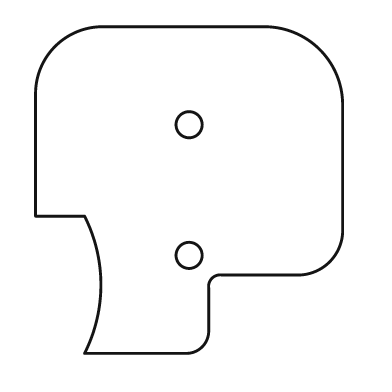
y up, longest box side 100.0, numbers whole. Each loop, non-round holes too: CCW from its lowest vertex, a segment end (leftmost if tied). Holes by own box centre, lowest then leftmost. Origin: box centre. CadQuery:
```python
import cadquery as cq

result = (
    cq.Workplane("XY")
    .moveTo(-32.0, -50.0)
    .lineTo(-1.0, -50.0)
    .threePointArc((4.0, -48.0), (6.0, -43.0))
    .lineTo(6.0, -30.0)
    .threePointArc((7.0, -27.0), (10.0, -26.0))
    .lineTo(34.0, -26.0)
    .threePointArc((43.0, -22.0), (47.0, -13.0))
    .lineTo(47.0, 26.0)
    .threePointArc((40.0, 43.0), (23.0, 50.0))
    .lineTo(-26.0, 50.0)
    .threePointArc((-41.0, 44.0), (-47.0, 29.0))
    .lineTo(-47.0, -8.0)
    .lineTo(-32.0, -8.0)
    .threePointArc((-27.0, -29.0), (-32.0, -50.0))
    .close()
    .moveTo(0.0, -20.0)
    .circle(4.0)
    .moveTo(0.0, 20.0)
    .circle(4.0)
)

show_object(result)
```